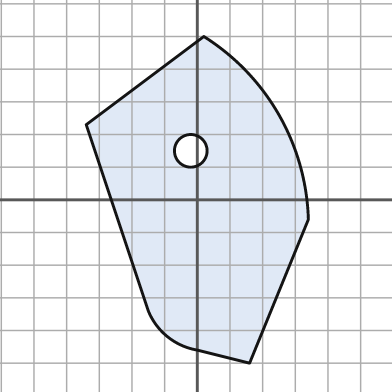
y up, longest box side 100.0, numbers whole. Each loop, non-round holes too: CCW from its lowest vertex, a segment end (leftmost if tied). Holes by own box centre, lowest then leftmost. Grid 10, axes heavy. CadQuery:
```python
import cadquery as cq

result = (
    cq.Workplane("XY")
    .moveTo(16.0, -50.0)
    .lineTo(34.0, -6.0)
    .threePointArc((25.0, 26.0), (2.0, 50.0))
    .lineTo(-34.0, 23.0)
    .lineTo(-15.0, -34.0)
    .threePointArc((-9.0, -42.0), (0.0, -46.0))
    .close()
    .moveTo(-2.0, 15.0)
    .circle(5.0)
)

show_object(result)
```